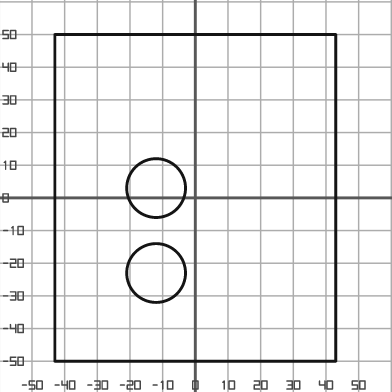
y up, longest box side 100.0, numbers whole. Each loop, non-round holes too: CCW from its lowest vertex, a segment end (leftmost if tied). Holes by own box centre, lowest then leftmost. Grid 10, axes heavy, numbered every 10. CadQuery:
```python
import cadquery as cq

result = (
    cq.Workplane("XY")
    .moveTo(-43.0, -50.0)
    .lineTo(43.0, -50.0)
    .lineTo(43.0, 50.0)
    .lineTo(-43.0, 50.0)
    .close()
    .moveTo(-12.0, -23.0)
    .circle(9.0)
    .moveTo(-12.0, 3.0)
    .circle(9.0)
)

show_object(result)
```